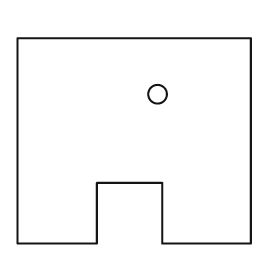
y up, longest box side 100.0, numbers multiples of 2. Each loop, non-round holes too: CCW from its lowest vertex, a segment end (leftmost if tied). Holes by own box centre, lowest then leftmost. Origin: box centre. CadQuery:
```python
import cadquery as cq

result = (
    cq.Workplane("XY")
    .moveTo(-50.0, -44.0)
    .lineTo(-16.0, -44.0)
    .lineTo(-16.0, -18.0)
    .lineTo(12.0, -18.0)
    .lineTo(12.0, -44.0)
    .lineTo(50.0, -44.0)
    .lineTo(50.0, 44.0)
    .lineTo(-50.0, 44.0)
    .close()
    .moveTo(10.0, 20.0)
    .circle(4.0)
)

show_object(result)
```